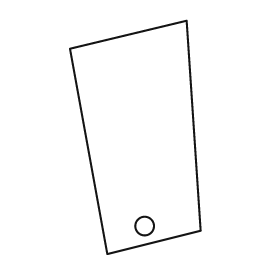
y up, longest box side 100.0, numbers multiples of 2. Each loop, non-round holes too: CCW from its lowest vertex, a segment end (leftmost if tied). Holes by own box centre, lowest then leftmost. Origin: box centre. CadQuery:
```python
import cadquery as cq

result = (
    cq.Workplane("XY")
    .moveTo(-12.0, -50.0)
    .lineTo(28.0, -40.0)
    .lineTo(22.0, 50.0)
    .lineTo(-28.0, 38.0)
    .close()
    .moveTo(4.0, -38.0)
    .circle(4.0)
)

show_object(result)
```